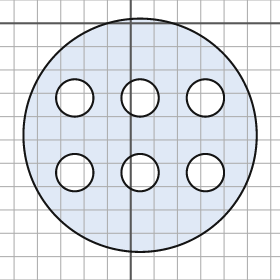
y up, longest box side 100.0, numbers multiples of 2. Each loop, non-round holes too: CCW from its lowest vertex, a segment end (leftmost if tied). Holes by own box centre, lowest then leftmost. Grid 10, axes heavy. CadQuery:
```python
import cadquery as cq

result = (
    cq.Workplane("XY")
    .moveTo(4.0, -48.0)
    .circle(50.0)
    .moveTo(-24.0, -64.0)
    .circle(8.0)
    .moveTo(4.0, -64.0)
    .circle(8.0)
    .moveTo(32.0, -64.0)
    .circle(8.0)
    .moveTo(-24.0, -32.0)
    .circle(8.0)
    .moveTo(4.0, -32.0)
    .circle(8.0)
    .moveTo(32.0, -32.0)
    .circle(8.0)
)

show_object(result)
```